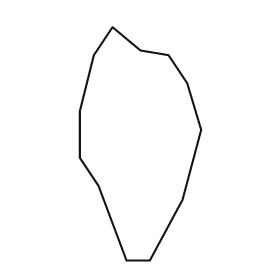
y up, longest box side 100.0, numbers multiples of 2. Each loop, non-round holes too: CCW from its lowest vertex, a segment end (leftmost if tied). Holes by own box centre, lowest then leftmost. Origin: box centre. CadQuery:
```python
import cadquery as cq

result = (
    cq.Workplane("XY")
    .moveTo(-6.0, -50.0)
    .lineTo(4.0, -50.0)
    .lineTo(18.0, -24.0)
    .lineTo(26.0, 6.0)
    .lineTo(20.0, 26.0)
    .lineTo(12.0, 38.0)
    .lineTo(0.0, 40.0)
    .lineTo(-12.0, 50.0)
    .lineTo(-20.0, 38.0)
    .lineTo(-26.0, 14.0)
    .lineTo(-26.0, -6.0)
    .lineTo(-18.0, -18.0)
    .close()
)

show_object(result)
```